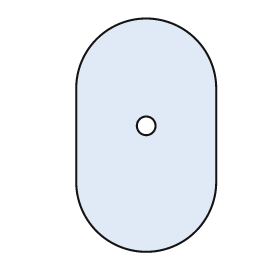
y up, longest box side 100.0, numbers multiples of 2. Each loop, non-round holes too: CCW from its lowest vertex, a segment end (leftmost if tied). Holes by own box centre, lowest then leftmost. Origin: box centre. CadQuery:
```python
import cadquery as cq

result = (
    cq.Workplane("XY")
    .moveTo(-30.0, -20.0)
    .threePointArc((0.0, -50.0), (30.0, -20.0))
    .lineTo(30.0, 20.0)
    .threePointArc((0.0, 50.0), (-30.0, 20.0))
    .close()
    .moveTo(0.0, 4.0)
    .circle(4.0)
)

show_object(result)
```